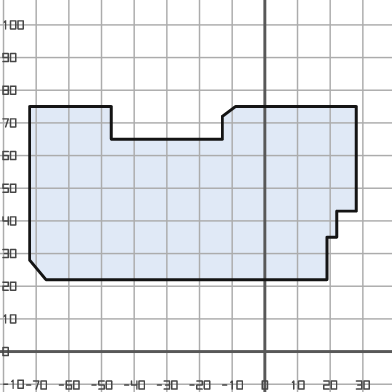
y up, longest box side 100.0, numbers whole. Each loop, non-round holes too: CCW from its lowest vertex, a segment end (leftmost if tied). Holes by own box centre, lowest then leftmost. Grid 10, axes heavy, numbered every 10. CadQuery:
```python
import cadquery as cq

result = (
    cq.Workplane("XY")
    .moveTo(-67.0, 22.0)
    .lineTo(19.0, 22.0)
    .lineTo(19.0, 35.0)
    .lineTo(22.0, 35.0)
    .lineTo(22.0, 43.0)
    .lineTo(28.0, 43.0)
    .lineTo(28.0, 75.0)
    .lineTo(-9.0, 75.0)
    .lineTo(-13.0, 72.0)
    .lineTo(-13.0, 65.0)
    .lineTo(-47.0, 65.0)
    .lineTo(-47.0, 75.0)
    .lineTo(-72.0, 75.0)
    .lineTo(-72.0, 28.0)
    .close()
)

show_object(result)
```